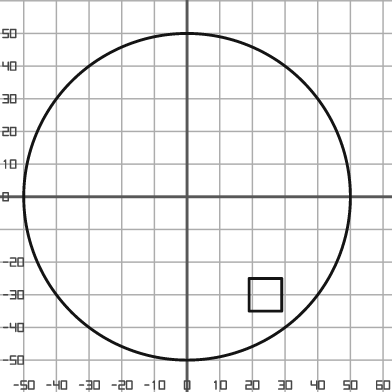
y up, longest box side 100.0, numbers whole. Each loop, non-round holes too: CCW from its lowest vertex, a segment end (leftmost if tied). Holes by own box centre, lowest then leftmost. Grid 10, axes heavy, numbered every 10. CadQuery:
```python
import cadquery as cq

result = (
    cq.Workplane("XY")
    .moveTo(0.0, 0.0)
    .circle(50.0)
    .moveTo(19.0, -35.0)
    .lineTo(29.0, -35.0)
    .lineTo(29.0, -25.0)
    .lineTo(19.0, -25.0)
    .close()
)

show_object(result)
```